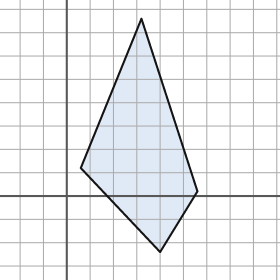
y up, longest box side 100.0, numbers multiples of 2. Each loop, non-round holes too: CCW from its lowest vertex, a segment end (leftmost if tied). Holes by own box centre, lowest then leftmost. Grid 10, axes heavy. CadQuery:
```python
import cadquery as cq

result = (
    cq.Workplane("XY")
    .moveTo(40.0, -24.0)
    .lineTo(56.0, 2.0)
    .lineTo(32.0, 76.0)
    .lineTo(6.0, 12.0)
    .close()
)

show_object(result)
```